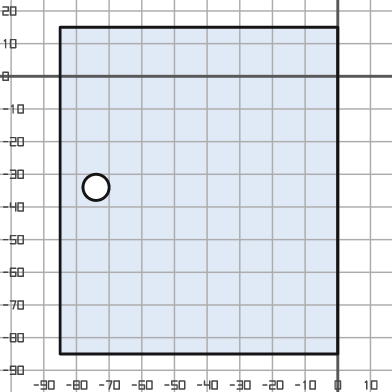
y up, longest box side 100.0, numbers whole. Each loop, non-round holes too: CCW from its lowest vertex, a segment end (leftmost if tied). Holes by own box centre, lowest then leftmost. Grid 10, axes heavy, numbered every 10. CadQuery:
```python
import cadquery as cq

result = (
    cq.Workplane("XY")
    .moveTo(-85.0, -85.0)
    .lineTo(0.0, -85.0)
    .lineTo(0.0, 15.0)
    .lineTo(-85.0, 15.0)
    .close()
    .moveTo(-74.0, -34.0)
    .circle(4.0)
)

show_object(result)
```